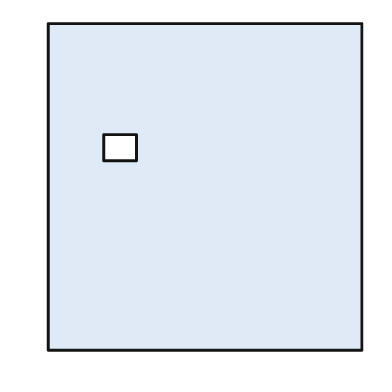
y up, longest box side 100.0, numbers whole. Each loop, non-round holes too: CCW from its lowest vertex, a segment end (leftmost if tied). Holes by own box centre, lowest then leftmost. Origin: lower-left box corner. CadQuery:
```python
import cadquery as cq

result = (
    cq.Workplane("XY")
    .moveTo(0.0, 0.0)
    .lineTo(96.0, 0.0)
    .lineTo(96.0, 100.0)
    .lineTo(0.0, 100.0)
    .close()
    .moveTo(17.0, 58.0)
    .lineTo(27.0, 58.0)
    .lineTo(27.0, 66.0)
    .lineTo(17.0, 66.0)
    .close()
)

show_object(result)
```